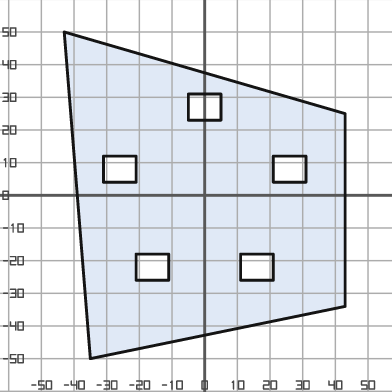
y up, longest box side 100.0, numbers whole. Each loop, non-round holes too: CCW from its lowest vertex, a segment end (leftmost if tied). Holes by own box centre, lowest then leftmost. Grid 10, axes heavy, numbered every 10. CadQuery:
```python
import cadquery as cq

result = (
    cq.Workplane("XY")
    .moveTo(-35.0, -50.0)
    .lineTo(43.0, -34.0)
    .lineTo(43.0, 25.0)
    .lineTo(-43.0, 50.0)
    .close()
    .moveTo(-21.0, -26.0)
    .lineTo(-11.0, -26.0)
    .lineTo(-11.0, -18.0)
    .lineTo(-21.0, -18.0)
    .close()
    .moveTo(11.0, -26.0)
    .lineTo(21.0, -26.0)
    .lineTo(21.0, -18.0)
    .lineTo(11.0, -18.0)
    .close()
    .moveTo(-31.0, 4.0)
    .lineTo(-21.0, 4.0)
    .lineTo(-21.0, 12.0)
    .lineTo(-31.0, 12.0)
    .close()
    .moveTo(21.0, 4.0)
    .lineTo(31.0, 4.0)
    .lineTo(31.0, 12.0)
    .lineTo(21.0, 12.0)
    .close()
    .moveTo(-5.0, 23.0)
    .lineTo(5.0, 23.0)
    .lineTo(5.0, 31.0)
    .lineTo(-5.0, 31.0)
    .close()
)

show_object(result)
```